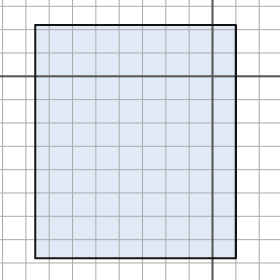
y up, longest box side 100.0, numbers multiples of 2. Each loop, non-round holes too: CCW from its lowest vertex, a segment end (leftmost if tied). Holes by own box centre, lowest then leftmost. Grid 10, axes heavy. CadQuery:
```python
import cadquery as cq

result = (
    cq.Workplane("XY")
    .moveTo(-76.0, -78.0)
    .lineTo(10.0, -78.0)
    .lineTo(10.0, 22.0)
    .lineTo(-76.0, 22.0)
    .close()
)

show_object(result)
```